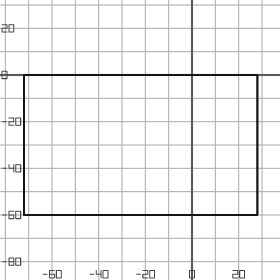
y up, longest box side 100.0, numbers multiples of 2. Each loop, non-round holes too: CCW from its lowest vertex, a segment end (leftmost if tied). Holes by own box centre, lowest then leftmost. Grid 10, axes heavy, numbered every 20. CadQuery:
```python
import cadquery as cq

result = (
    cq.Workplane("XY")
    .moveTo(-72.0, -60.0)
    .lineTo(28.0, -60.0)
    .lineTo(28.0, 0.0)
    .lineTo(-72.0, 0.0)
    .close()
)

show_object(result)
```